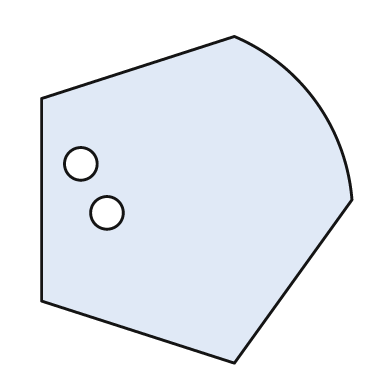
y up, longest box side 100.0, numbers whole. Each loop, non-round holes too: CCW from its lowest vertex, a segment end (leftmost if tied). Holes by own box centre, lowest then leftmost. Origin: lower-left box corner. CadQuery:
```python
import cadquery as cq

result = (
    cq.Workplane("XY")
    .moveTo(59.0, 0.0)
    .lineTo(95.0, 50.0)
    .threePointArc((84.0, 80.0), (59.0, 100.0))
    .lineTo(0.0, 81.0)
    .lineTo(0.0, 19.0)
    .close()
    .moveTo(20.0, 46.0)
    .circle(5.0)
    .moveTo(12.0, 61.0)
    .circle(5.0)
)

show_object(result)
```